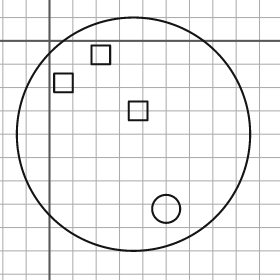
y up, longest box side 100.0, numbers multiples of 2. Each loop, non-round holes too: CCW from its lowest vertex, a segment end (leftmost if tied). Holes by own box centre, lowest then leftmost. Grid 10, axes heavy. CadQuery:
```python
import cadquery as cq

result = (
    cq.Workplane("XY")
    .moveTo(36.0, -40.0)
    .circle(50.0)
    .moveTo(50.0, -72.0)
    .circle(6.0)
    .moveTo(34.0, -34.0)
    .lineTo(42.0, -34.0)
    .lineTo(42.0, -26.0)
    .lineTo(34.0, -26.0)
    .close()
    .moveTo(2.0, -22.0)
    .lineTo(10.0, -22.0)
    .lineTo(10.0, -14.0)
    .lineTo(2.0, -14.0)
    .close()
    .moveTo(18.0, -10.0)
    .lineTo(26.0, -10.0)
    .lineTo(26.0, -2.0)
    .lineTo(18.0, -2.0)
    .close()
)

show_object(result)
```